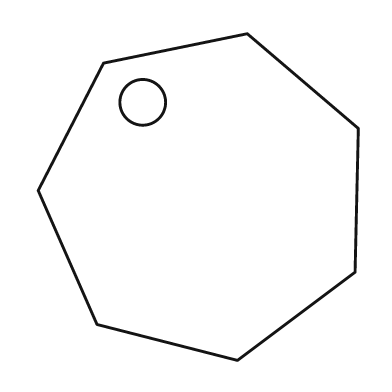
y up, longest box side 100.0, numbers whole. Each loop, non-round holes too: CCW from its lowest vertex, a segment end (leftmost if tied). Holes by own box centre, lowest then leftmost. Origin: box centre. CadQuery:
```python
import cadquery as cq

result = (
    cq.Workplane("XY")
    .moveTo(12.0, -50.0)
    .lineTo(48.0, -23.0)
    .lineTo(49.0, 21.0)
    .lineTo(15.0, 50.0)
    .lineTo(-29.0, 41.0)
    .lineTo(-49.0, 2.0)
    .lineTo(-31.0, -39.0)
    .close()
    .moveTo(-17.0, 29.0)
    .circle(7.0)
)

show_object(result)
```